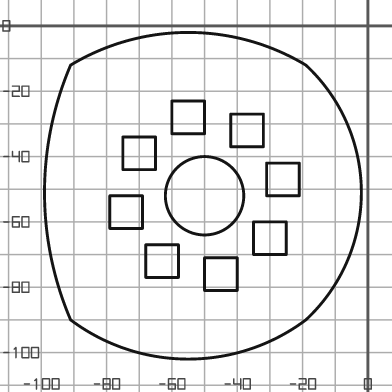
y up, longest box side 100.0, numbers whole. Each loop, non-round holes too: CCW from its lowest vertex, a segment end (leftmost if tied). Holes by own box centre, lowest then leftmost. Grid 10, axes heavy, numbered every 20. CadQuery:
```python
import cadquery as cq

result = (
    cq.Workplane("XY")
    .moveTo(-91.0, -90.0)
    .threePointArc((-55.0, -102.0), (-19.0, -90.0))
    .threePointArc((-2.0, -51.0), (-19.0, -12.0))
    .threePointArc((-55.0, -2.0), (-91.0, -12.0))
    .threePointArc((-99.0, -51.0), (-91.0, -90.0))
    .close()
    .moveTo(-50.0, -81.0)
    .lineTo(-40.0, -81.0)
    .lineTo(-40.0, -71.0)
    .lineTo(-50.0, -71.0)
    .close()
    .moveTo(-68.0, -77.0)
    .lineTo(-58.0, -77.0)
    .lineTo(-58.0, -67.0)
    .lineTo(-68.0, -67.0)
    .close()
    .moveTo(-35.0, -70.0)
    .lineTo(-25.0, -70.0)
    .lineTo(-25.0, -60.0)
    .lineTo(-35.0, -60.0)
    .close()
    .moveTo(-79.0, -62.0)
    .lineTo(-69.0, -62.0)
    .lineTo(-69.0, -52.0)
    .lineTo(-79.0, -52.0)
    .close()
    .moveTo(-50.0, -52.0)
    .circle(12.0)
    .moveTo(-31.0, -52.0)
    .lineTo(-21.0, -52.0)
    .lineTo(-21.0, -42.0)
    .lineTo(-31.0, -42.0)
    .close()
    .moveTo(-75.0, -44.0)
    .lineTo(-65.0, -44.0)
    .lineTo(-65.0, -34.0)
    .lineTo(-75.0, -34.0)
    .close()
    .moveTo(-42.0, -37.0)
    .lineTo(-32.0, -37.0)
    .lineTo(-32.0, -27.0)
    .lineTo(-42.0, -27.0)
    .close()
    .moveTo(-60.0, -33.0)
    .lineTo(-50.0, -33.0)
    .lineTo(-50.0, -23.0)
    .lineTo(-60.0, -23.0)
    .close()
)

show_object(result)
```